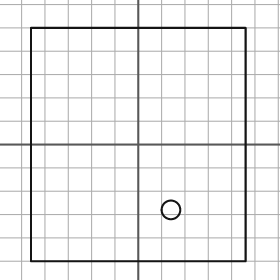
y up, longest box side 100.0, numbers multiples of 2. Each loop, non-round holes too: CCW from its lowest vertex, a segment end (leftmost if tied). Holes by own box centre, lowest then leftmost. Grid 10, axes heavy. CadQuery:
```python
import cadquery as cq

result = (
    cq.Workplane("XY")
    .moveTo(-46.0, -50.0)
    .lineTo(46.0, -50.0)
    .lineTo(46.0, 50.0)
    .lineTo(-46.0, 50.0)
    .close()
    .moveTo(14.0, -28.0)
    .circle(4.0)
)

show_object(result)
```